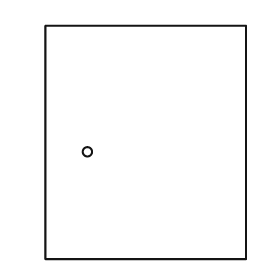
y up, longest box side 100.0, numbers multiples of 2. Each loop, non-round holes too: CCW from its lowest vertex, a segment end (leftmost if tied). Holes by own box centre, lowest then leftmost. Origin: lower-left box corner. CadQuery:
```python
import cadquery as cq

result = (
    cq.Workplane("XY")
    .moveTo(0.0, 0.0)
    .lineTo(86.0, 0.0)
    .lineTo(86.0, 100.0)
    .lineTo(0.0, 100.0)
    .close()
    .moveTo(18.0, 46.0)
    .circle(2.0)
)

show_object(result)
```